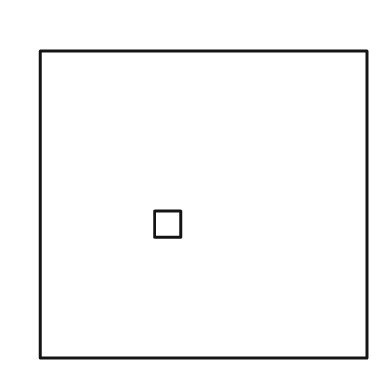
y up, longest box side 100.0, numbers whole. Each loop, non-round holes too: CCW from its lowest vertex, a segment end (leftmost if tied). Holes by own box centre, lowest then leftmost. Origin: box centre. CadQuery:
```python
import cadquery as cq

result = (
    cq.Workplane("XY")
    .moveTo(-50.0, -47.0)
    .lineTo(50.0, -47.0)
    .lineTo(50.0, 47.0)
    .lineTo(-50.0, 47.0)
    .close()
    .moveTo(-15.0, -10.0)
    .lineTo(-7.0, -10.0)
    .lineTo(-7.0, -2.0)
    .lineTo(-15.0, -2.0)
    .close()
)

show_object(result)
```